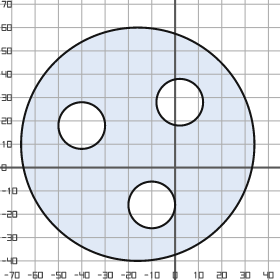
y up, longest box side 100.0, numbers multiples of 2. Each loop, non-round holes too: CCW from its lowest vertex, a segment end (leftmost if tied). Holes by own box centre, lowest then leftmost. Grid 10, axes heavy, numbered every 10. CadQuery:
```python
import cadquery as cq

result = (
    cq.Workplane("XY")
    .moveTo(-16.0, 10.0)
    .circle(50.0)
    .moveTo(-10.0, -16.0)
    .circle(10.0)
    .moveTo(-40.0, 18.0)
    .circle(10.0)
    .moveTo(2.0, 28.0)
    .circle(10.0)
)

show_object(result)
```